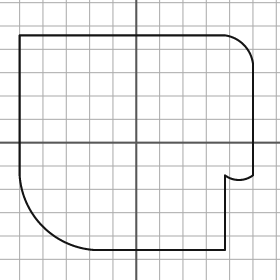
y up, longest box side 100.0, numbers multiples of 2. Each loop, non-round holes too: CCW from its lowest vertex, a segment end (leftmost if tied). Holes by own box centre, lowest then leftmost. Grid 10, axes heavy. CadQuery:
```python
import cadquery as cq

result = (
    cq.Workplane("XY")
    .moveTo(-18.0, -46.0)
    .lineTo(38.0, -46.0)
    .lineTo(38.0, -14.0)
    .threePointArc((44.0, -16.0), (50.0, -14.0))
    .lineTo(50.0, 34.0)
    .threePointArc((46.0, 42.0), (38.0, 46.0))
    .lineTo(-50.0, 46.0)
    .lineTo(-50.0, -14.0)
    .threePointArc((-40.0, -36.0), (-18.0, -46.0))
    .close()
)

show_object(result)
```